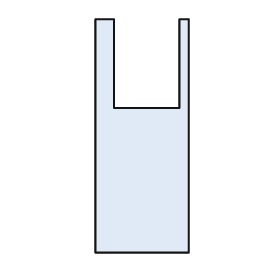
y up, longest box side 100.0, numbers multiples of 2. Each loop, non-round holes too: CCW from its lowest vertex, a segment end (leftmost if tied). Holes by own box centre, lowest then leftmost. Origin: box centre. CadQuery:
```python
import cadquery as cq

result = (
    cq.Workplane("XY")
    .moveTo(-20.0, -50.0)
    .lineTo(20.0, -50.0)
    .lineTo(20.0, 50.0)
    .lineTo(16.0, 50.0)
    .lineTo(16.0, 12.0)
    .lineTo(-12.0, 12.0)
    .lineTo(-12.0, 50.0)
    .lineTo(-20.0, 50.0)
    .close()
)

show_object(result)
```